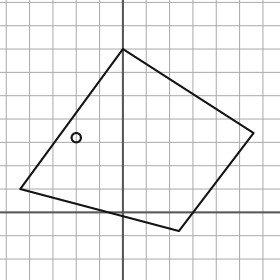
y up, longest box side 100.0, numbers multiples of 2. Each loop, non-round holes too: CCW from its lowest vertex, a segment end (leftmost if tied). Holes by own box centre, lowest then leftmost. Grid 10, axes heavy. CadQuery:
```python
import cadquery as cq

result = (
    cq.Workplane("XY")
    .moveTo(24.0, -8.0)
    .lineTo(56.0, 34.0)
    .lineTo(0.0, 70.0)
    .lineTo(-44.0, 10.0)
    .close()
    .moveTo(-20.0, 32.0)
    .circle(2.0)
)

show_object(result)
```